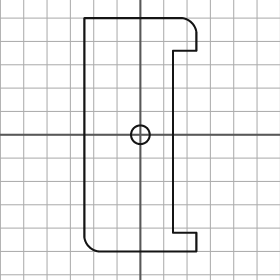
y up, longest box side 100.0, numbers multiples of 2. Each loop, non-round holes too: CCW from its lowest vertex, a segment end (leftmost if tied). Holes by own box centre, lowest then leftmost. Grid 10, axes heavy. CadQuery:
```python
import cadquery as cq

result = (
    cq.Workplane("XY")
    .moveTo(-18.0, -50.0)
    .lineTo(24.0, -50.0)
    .lineTo(24.0, -42.0)
    .lineTo(14.0, -42.0)
    .lineTo(14.0, 36.0)
    .lineTo(24.0, 36.0)
    .lineTo(24.0, 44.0)
    .threePointArc((22.0, 48.0), (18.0, 50.0))
    .lineTo(-24.0, 50.0)
    .lineTo(-24.0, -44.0)
    .threePointArc((-22.0, -48.0), (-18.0, -50.0))
    .close()
    .moveTo(0.0, 0.0)
    .circle(4.0)
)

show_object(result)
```